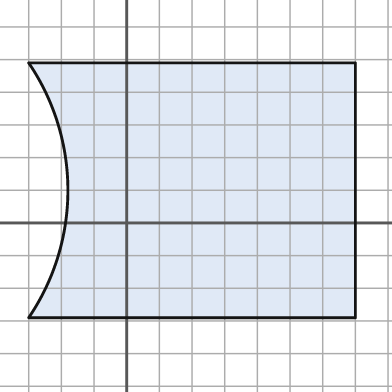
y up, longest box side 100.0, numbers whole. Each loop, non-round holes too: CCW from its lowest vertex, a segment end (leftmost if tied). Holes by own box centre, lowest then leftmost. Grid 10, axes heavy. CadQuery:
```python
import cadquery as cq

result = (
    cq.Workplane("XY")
    .moveTo(-30.0, -29.0)
    .lineTo(70.0, -29.0)
    .lineTo(70.0, 49.0)
    .lineTo(-30.0, 49.0)
    .threePointArc((-18.0, 10.0), (-30.0, -29.0))
    .close()
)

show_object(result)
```